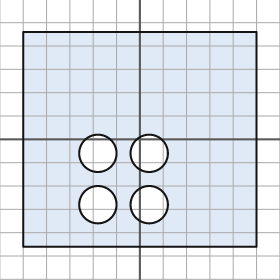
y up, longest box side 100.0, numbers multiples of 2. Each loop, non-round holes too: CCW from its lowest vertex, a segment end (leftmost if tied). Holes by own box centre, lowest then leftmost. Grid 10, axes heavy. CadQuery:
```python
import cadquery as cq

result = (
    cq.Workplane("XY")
    .moveTo(-50.0, -46.0)
    .lineTo(50.0, -46.0)
    .lineTo(50.0, 46.0)
    .lineTo(-50.0, 46.0)
    .close()
    .moveTo(-18.0, -28.0)
    .circle(8.0)
    .moveTo(4.0, -28.0)
    .circle(8.0)
    .moveTo(-18.0, -6.0)
    .circle(8.0)
    .moveTo(4.0, -6.0)
    .circle(8.0)
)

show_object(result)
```